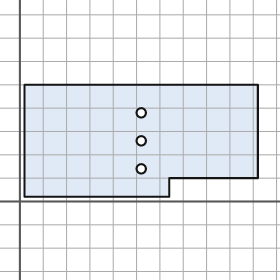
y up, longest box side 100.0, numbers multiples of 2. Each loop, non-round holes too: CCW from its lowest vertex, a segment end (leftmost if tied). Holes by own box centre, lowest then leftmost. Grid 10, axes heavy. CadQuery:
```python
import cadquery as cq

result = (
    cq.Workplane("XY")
    .moveTo(2.0, 2.0)
    .lineTo(64.0, 2.0)
    .lineTo(64.0, 10.0)
    .lineTo(102.0, 10.0)
    .lineTo(102.0, 50.0)
    .lineTo(2.0, 50.0)
    .close()
    .moveTo(52.0, 14.0)
    .circle(2.0)
    .moveTo(52.0, 26.0)
    .circle(2.0)
    .moveTo(52.0, 38.0)
    .circle(2.0)
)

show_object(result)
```